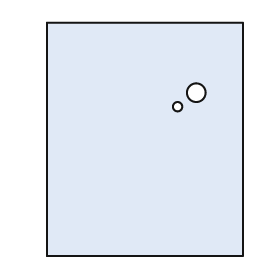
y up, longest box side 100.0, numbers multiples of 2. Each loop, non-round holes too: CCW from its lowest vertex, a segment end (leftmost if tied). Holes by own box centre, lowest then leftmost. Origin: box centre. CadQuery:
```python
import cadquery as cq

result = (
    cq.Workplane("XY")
    .moveTo(-42.0, -50.0)
    .lineTo(42.0, -50.0)
    .lineTo(42.0, 50.0)
    .lineTo(-42.0, 50.0)
    .close()
    .moveTo(14.0, 14.0)
    .circle(2.0)
    .moveTo(22.0, 20.0)
    .circle(4.0)
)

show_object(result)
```